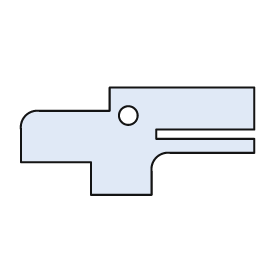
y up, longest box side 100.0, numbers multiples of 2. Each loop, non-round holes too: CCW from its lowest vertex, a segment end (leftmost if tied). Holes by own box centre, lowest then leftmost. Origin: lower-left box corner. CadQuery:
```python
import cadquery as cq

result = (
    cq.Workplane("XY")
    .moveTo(30.0, 0.0)
    .lineTo(56.0, 0.0)
    .lineTo(56.0, 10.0)
    .threePointArc((58.0, 16.0), (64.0, 18.0))
    .lineTo(100.0, 18.0)
    .lineTo(100.0, 24.0)
    .lineTo(58.0, 24.0)
    .lineTo(58.0, 28.0)
    .lineTo(100.0, 28.0)
    .lineTo(100.0, 46.0)
    .lineTo(38.0, 46.0)
    .lineTo(38.0, 36.0)
    .lineTo(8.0, 36.0)
    .threePointArc((2.0, 34.0), (0.0, 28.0))
    .lineTo(0.0, 14.0)
    .lineTo(30.0, 14.0)
    .close()
    .moveTo(46.0, 34.0)
    .circle(4.0)
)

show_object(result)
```